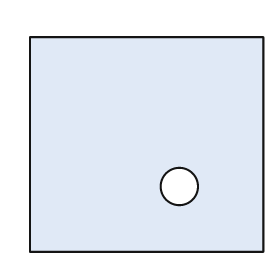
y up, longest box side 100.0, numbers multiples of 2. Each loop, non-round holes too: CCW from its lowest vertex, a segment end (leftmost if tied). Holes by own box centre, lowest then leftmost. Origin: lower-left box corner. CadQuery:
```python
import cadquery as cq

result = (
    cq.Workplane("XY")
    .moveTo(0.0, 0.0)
    .lineTo(100.0, 0.0)
    .lineTo(100.0, 92.0)
    .lineTo(0.0, 92.0)
    .close()
    .moveTo(64.0, 28.0)
    .circle(8.0)
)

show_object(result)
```